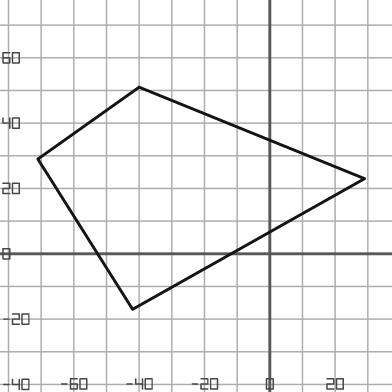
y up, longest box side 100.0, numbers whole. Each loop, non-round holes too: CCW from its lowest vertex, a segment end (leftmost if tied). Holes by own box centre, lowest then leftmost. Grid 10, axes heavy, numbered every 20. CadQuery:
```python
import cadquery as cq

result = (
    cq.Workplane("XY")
    .moveTo(-42.0, -17.0)
    .lineTo(29.0, 23.0)
    .lineTo(-40.0, 51.0)
    .lineTo(-71.0, 29.0)
    .close()
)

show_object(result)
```